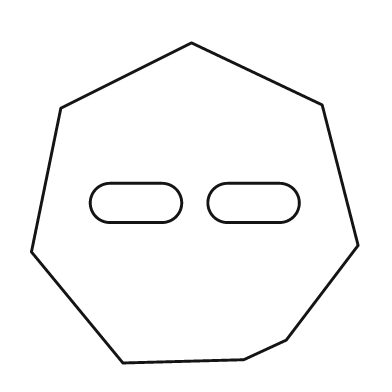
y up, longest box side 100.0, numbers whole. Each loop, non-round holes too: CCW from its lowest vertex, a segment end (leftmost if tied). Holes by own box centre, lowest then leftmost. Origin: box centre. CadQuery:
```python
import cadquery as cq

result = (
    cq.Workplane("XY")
    .moveTo(-22.0, -49.0)
    .lineTo(15.0, -48.0)
    .lineTo(28.0, -42.0)
    .lineTo(50.0, -13.0)
    .lineTo(39.0, 30.0)
    .lineTo(-1.0, 49.0)
    .lineTo(-41.0, 29.0)
    .lineTo(-50.0, -15.0)
    .close()
    .moveTo(-26.0, -6.0)
    .lineTo(-10.0, -6.0)
    .threePointArc((-4.0, 0.0), (-10.0, 6.0))
    .lineTo(-26.0, 6.0)
    .threePointArc((-32.0, 0.0), (-26.0, -6.0))
    .close()
    .moveTo(10.0, -6.0)
    .lineTo(26.0, -6.0)
    .threePointArc((32.0, 0.0), (26.0, 6.0))
    .lineTo(10.0, 6.0)
    .threePointArc((4.0, 0.0), (10.0, -6.0))
    .close()
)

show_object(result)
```